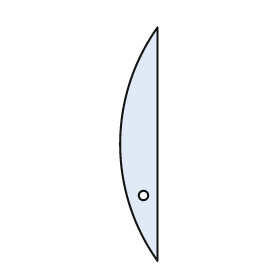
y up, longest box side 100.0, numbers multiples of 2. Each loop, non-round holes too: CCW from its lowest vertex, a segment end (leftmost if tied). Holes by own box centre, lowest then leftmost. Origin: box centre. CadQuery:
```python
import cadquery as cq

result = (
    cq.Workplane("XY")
    .moveTo(8.0, -50.0)
    .lineTo(8.0, 50.0)
    .threePointArc((-8.0, 0.0), (8.0, -50.0))
    .close()
    .moveTo(2.0, -22.0)
    .circle(2.0)
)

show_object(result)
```